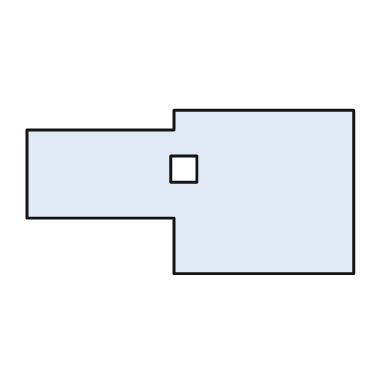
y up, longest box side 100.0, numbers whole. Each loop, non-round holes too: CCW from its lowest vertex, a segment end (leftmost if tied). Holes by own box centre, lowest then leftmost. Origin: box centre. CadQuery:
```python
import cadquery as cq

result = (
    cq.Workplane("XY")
    .moveTo(-5.0, -25.0)
    .lineTo(50.0, -25.0)
    .lineTo(50.0, 25.0)
    .lineTo(-5.0, 25.0)
    .lineTo(-5.0, 19.0)
    .lineTo(-50.0, 19.0)
    .lineTo(-50.0, -8.0)
    .lineTo(-5.0, -8.0)
    .close()
    .moveTo(-6.0, 3.0)
    .lineTo(2.0, 3.0)
    .lineTo(2.0, 11.0)
    .lineTo(-6.0, 11.0)
    .close()
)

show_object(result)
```